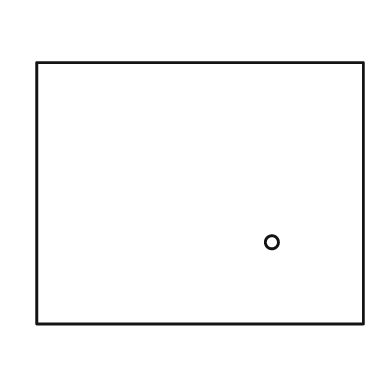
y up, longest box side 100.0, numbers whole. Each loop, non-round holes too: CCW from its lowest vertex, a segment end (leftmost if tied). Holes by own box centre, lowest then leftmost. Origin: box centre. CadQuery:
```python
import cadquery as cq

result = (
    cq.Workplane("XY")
    .moveTo(-50.0, -40.0)
    .lineTo(50.0, -40.0)
    .lineTo(50.0, 40.0)
    .lineTo(-50.0, 40.0)
    .close()
    .moveTo(22.0, -15.0)
    .circle(2.0)
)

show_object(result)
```